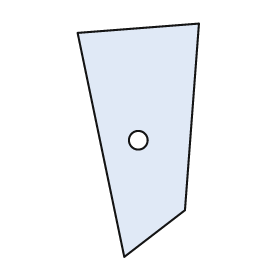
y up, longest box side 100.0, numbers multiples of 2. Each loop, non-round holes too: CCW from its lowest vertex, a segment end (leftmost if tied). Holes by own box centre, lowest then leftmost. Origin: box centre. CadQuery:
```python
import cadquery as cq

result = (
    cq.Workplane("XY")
    .moveTo(-6.0, -50.0)
    .lineTo(20.0, -30.0)
    .lineTo(26.0, 50.0)
    .lineTo(-26.0, 46.0)
    .close()
    .moveTo(0.0, 0.0)
    .circle(4.0)
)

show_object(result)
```